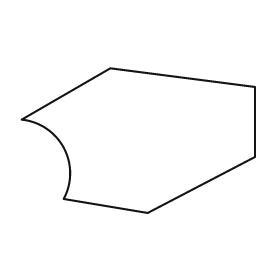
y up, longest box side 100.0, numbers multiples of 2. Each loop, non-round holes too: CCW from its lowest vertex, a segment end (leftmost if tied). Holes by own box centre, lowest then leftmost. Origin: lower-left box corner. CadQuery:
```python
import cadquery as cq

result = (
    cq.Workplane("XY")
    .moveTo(54.0, 0.0)
    .lineTo(100.0, 24.0)
    .lineTo(100.0, 54.0)
    .lineTo(38.0, 62.0)
    .lineTo(0.0, 40.0)
    .threePointArc((18.0, 28.0), (18.0, 6.0))
    .close()
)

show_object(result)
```